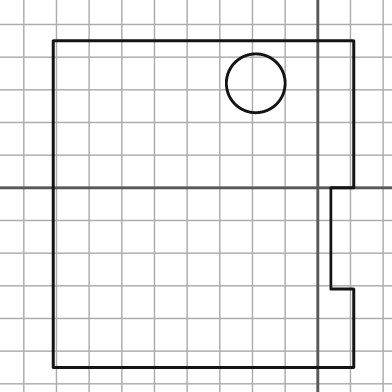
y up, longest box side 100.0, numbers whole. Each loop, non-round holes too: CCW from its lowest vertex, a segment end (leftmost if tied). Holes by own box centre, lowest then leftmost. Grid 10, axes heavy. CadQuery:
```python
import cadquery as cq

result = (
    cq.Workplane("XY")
    .moveTo(-81.0, -55.0)
    .lineTo(11.0, -55.0)
    .lineTo(11.0, -31.0)
    .lineTo(4.0, -31.0)
    .lineTo(4.0, 0.0)
    .lineTo(11.0, 0.0)
    .lineTo(11.0, 45.0)
    .lineTo(-81.0, 45.0)
    .close()
    .moveTo(-19.0, 32.0)
    .circle(9.0)
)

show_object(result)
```